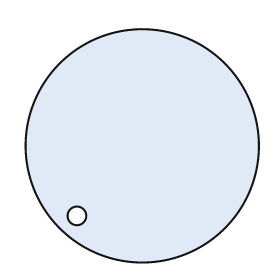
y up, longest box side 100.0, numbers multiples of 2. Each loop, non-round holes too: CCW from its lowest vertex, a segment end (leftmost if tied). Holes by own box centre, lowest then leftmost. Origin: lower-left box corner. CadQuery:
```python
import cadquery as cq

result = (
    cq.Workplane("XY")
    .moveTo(50.0, 50.0)
    .circle(50.0)
    .moveTo(22.0, 20.0)
    .circle(4.0)
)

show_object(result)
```